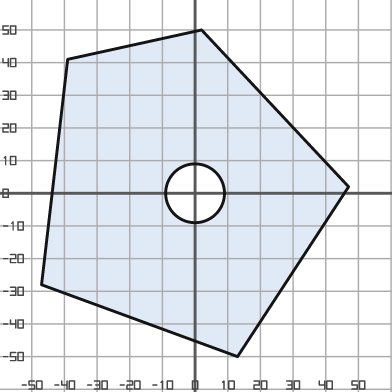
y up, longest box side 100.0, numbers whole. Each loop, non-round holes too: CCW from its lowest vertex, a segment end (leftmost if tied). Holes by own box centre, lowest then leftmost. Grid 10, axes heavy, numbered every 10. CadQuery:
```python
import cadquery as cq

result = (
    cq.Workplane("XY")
    .moveTo(13.0, -50.0)
    .lineTo(47.0, 2.0)
    .lineTo(2.0, 50.0)
    .lineTo(-39.0, 41.0)
    .lineTo(-47.0, -28.0)
    .close()
    .moveTo(0.0, 0.0)
    .circle(9.0)
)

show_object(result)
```